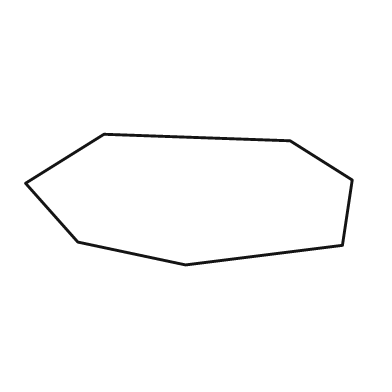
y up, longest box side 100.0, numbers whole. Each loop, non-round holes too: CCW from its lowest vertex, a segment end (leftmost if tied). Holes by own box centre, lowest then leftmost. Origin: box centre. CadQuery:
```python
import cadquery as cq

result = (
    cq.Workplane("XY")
    .moveTo(-1.0, -20.0)
    .lineTo(47.0, -14.0)
    .lineTo(50.0, 6.0)
    .lineTo(31.0, 18.0)
    .lineTo(-26.0, 20.0)
    .lineTo(-50.0, 5.0)
    .lineTo(-34.0, -13.0)
    .close()
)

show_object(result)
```